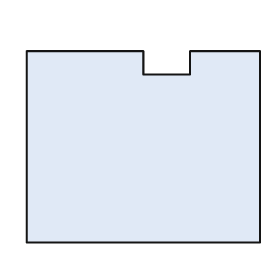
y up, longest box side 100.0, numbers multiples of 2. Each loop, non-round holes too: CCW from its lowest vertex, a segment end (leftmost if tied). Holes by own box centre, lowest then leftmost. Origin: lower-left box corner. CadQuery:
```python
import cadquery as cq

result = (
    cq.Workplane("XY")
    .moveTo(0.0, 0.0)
    .lineTo(100.0, 0.0)
    .lineTo(100.0, 82.0)
    .lineTo(70.0, 82.0)
    .lineTo(70.0, 72.0)
    .lineTo(50.0, 72.0)
    .lineTo(50.0, 82.0)
    .lineTo(0.0, 82.0)
    .close()
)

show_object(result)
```